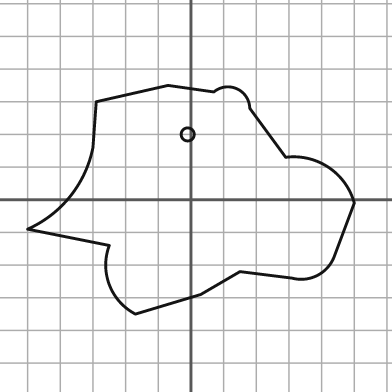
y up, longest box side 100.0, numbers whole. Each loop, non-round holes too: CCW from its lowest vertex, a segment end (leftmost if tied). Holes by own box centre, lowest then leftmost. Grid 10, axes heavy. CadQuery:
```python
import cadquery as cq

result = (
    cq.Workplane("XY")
    .moveTo(-17.0, -35.0)
    .lineTo(3.0, -29.0)
    .lineTo(15.0, -22.0)
    .lineTo(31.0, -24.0)
    .threePointArc((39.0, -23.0), (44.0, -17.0))
    .lineTo(50.0, -1.0)
    .threePointArc((42.0, 10.0), (29.0, 13.0))
    .lineTo(18.0, 28.0)
    .threePointArc((14.0, 34.0), (7.0, 33.0))
    .lineTo(-7.0, 35.0)
    .lineTo(-29.0, 30.0)
    .lineTo(-30.0, 16.0)
    .threePointArc((-37.0, 1.0), (-50.0, -9.0))
    .lineTo(-25.0, -14.0)
    .threePointArc((-25.0, -26.0), (-17.0, -35.0))
    .close()
    .moveTo(-1.0, 20.0)
    .circle(2.0)
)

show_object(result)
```